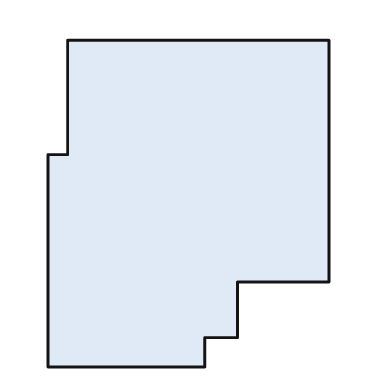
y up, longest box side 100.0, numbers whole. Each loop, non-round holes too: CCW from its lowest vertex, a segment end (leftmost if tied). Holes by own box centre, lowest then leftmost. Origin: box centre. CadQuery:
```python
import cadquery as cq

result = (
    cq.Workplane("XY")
    .moveTo(-43.0, -50.0)
    .lineTo(5.0, -50.0)
    .lineTo(5.0, -41.0)
    .lineTo(15.0, -41.0)
    .lineTo(15.0, -24.0)
    .lineTo(43.0, -24.0)
    .lineTo(43.0, 50.0)
    .lineTo(-37.0, 50.0)
    .lineTo(-37.0, 15.0)
    .lineTo(-43.0, 15.0)
    .close()
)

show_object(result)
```